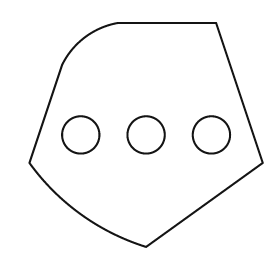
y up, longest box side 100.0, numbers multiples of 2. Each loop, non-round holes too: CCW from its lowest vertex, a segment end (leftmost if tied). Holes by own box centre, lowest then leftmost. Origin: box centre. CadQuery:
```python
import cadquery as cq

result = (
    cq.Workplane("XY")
    .moveTo(0.0, -48.0)
    .lineTo(50.0, -12.0)
    .lineTo(30.0, 48.0)
    .lineTo(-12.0, 48.0)
    .threePointArc((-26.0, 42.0), (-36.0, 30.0))
    .lineTo(-50.0, -12.0)
    .threePointArc((-28.0, -34.0), (0.0, -48.0))
    .close()
    .moveTo(-28.0, 0.0)
    .circle(8.0)
    .moveTo(0.0, 0.0)
    .circle(8.0)
    .moveTo(28.0, 0.0)
    .circle(8.0)
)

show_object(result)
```